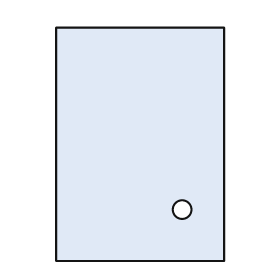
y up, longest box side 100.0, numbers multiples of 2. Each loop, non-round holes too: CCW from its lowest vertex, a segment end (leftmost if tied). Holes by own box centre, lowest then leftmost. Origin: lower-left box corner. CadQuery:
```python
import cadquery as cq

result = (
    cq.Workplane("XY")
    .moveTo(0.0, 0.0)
    .lineTo(72.0, 0.0)
    .lineTo(72.0, 100.0)
    .lineTo(0.0, 100.0)
    .close()
    .moveTo(54.0, 22.0)
    .circle(4.0)
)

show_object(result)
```